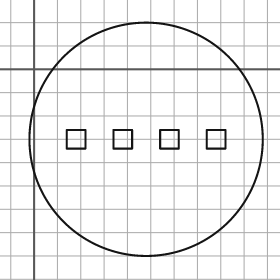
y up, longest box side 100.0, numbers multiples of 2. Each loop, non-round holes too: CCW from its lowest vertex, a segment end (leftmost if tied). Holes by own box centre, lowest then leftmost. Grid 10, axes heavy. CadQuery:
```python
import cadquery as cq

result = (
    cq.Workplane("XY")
    .moveTo(48.0, -30.0)
    .circle(50.0)
    .moveTo(14.0, -34.0)
    .lineTo(22.0, -34.0)
    .lineTo(22.0, -26.0)
    .lineTo(14.0, -26.0)
    .close()
    .moveTo(34.0, -34.0)
    .lineTo(42.0, -34.0)
    .lineTo(42.0, -26.0)
    .lineTo(34.0, -26.0)
    .close()
    .moveTo(54.0, -34.0)
    .lineTo(62.0, -34.0)
    .lineTo(62.0, -26.0)
    .lineTo(54.0, -26.0)
    .close()
    .moveTo(74.0, -34.0)
    .lineTo(82.0, -34.0)
    .lineTo(82.0, -26.0)
    .lineTo(74.0, -26.0)
    .close()
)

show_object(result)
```